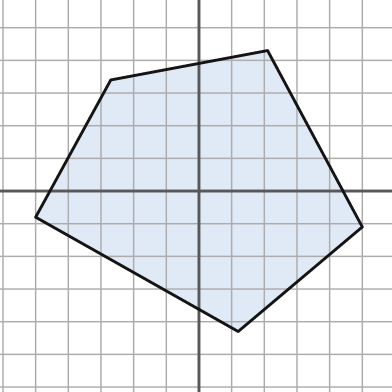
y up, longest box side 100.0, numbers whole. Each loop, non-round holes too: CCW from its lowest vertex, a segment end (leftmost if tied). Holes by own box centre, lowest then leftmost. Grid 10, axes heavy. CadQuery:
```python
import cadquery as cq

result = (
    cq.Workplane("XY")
    .moveTo(12.0, -43.0)
    .lineTo(50.0, -11.0)
    .lineTo(21.0, 43.0)
    .lineTo(-27.0, 34.0)
    .lineTo(-50.0, -8.0)
    .close()
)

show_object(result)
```